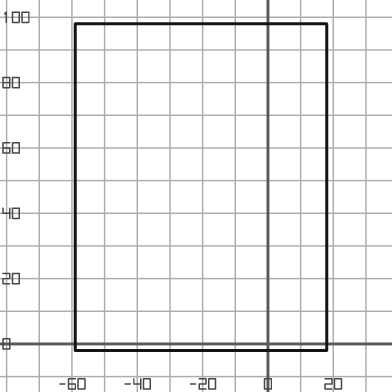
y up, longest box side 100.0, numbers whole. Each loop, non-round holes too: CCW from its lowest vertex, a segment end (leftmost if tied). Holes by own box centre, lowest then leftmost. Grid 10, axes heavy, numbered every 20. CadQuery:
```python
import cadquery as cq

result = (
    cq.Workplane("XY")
    .moveTo(-59.0, -2.0)
    .lineTo(18.0, -2.0)
    .lineTo(18.0, 98.0)
    .lineTo(-59.0, 98.0)
    .close()
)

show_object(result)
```